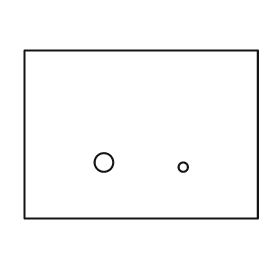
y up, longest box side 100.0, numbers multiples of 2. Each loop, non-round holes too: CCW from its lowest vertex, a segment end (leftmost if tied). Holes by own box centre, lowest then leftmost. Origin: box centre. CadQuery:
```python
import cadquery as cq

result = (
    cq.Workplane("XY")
    .moveTo(-50.0, -36.0)
    .lineTo(50.0, -36.0)
    .lineTo(50.0, 36.0)
    .lineTo(-50.0, 36.0)
    .close()
    .moveTo(18.0, -14.0)
    .circle(2.0)
    .moveTo(-16.0, -12.0)
    .circle(4.0)
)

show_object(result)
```